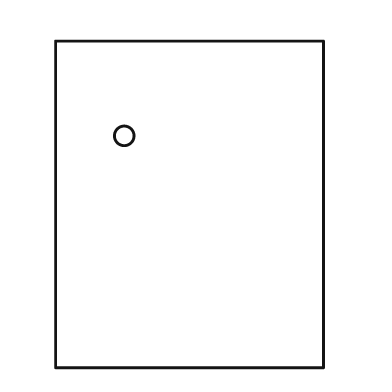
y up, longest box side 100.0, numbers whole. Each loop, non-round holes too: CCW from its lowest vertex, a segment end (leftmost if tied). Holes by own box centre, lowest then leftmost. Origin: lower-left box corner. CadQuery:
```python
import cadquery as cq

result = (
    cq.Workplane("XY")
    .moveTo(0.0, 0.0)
    .lineTo(82.0, 0.0)
    .lineTo(82.0, 100.0)
    .lineTo(0.0, 100.0)
    .close()
    .moveTo(21.0, 71.0)
    .circle(3.0)
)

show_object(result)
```